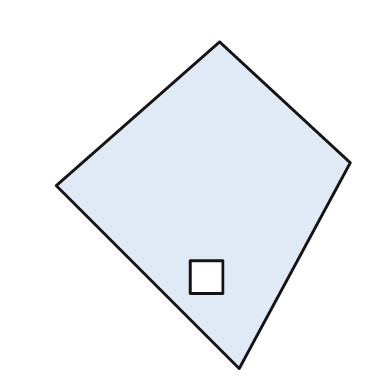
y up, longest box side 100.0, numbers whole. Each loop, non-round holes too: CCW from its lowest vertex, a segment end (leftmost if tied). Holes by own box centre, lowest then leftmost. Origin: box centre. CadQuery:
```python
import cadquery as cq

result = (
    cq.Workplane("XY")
    .moveTo(11.0, -50.0)
    .lineTo(45.0, 13.0)
    .lineTo(5.0, 50.0)
    .lineTo(-45.0, 6.0)
    .close()
    .moveTo(-4.0, -27.0)
    .lineTo(6.0, -27.0)
    .lineTo(6.0, -17.0)
    .lineTo(-4.0, -17.0)
    .close()
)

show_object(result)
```